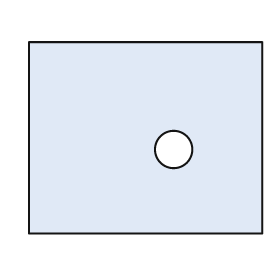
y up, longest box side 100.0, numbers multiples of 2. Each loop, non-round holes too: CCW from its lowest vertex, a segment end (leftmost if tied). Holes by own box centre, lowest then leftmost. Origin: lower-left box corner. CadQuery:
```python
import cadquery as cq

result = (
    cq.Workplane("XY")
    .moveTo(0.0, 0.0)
    .lineTo(100.0, 0.0)
    .lineTo(100.0, 82.0)
    .lineTo(0.0, 82.0)
    .close()
    .moveTo(62.0, 36.0)
    .circle(8.0)
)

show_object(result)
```